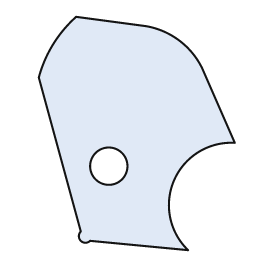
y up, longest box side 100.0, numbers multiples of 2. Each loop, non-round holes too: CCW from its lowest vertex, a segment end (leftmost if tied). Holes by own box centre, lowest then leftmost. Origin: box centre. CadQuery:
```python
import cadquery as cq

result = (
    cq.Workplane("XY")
    .moveTo(22.0, -50.0)
    .threePointArc((16.0, -20.0), (42.0, -4.0))
    .lineTo(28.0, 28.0)
    .threePointArc((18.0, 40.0), (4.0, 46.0))
    .lineTo(-26.0, 50.0)
    .threePointArc((-36.0, 38.0), (-42.0, 24.0))
    .lineTo(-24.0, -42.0)
    .threePointArc((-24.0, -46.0), (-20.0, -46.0))
    .close()
    .moveTo(-12.0, -14.0)
    .circle(8.0)
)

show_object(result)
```